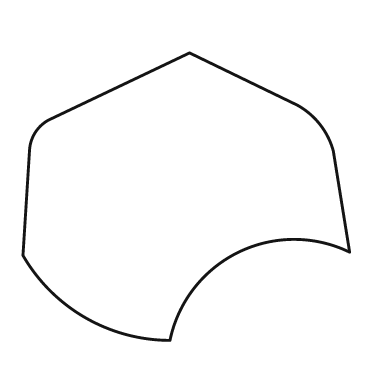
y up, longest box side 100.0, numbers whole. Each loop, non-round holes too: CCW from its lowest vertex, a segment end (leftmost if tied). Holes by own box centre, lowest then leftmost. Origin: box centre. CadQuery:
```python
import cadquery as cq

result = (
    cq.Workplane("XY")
    .moveTo(-5.0, -44.0)
    .threePointArc((16.0, -17.0), (50.0, -17.0))
    .lineTo(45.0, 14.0)
    .threePointArc((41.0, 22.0), (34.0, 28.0))
    .lineTo(1.0, 44.0)
    .lineTo(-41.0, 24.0)
    .threePointArc((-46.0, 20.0), (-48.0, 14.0))
    .lineTo(-50.0, -18.0)
    .threePointArc((-31.0, -37.0), (-5.0, -44.0))
    .close()
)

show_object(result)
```